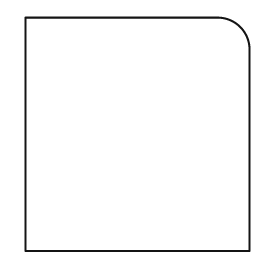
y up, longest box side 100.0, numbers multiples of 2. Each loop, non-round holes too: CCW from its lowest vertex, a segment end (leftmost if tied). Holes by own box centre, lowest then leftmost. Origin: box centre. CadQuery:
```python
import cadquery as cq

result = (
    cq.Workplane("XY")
    .moveTo(-48.0, -50.0)
    .lineTo(48.0, -50.0)
    .lineTo(48.0, 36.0)
    .threePointArc((44.0, 46.0), (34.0, 50.0))
    .lineTo(-48.0, 50.0)
    .close()
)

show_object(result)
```